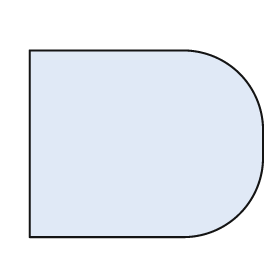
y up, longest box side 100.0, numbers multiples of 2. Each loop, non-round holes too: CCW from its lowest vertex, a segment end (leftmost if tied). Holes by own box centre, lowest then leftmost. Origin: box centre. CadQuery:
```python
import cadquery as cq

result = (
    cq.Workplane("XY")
    .moveTo(-50.0, -40.0)
    .lineTo(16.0, -40.0)
    .threePointArc((40.0, -30.0), (50.0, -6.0))
    .lineTo(50.0, 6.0)
    .threePointArc((40.0, 30.0), (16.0, 40.0))
    .lineTo(-50.0, 40.0)
    .close()
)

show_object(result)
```